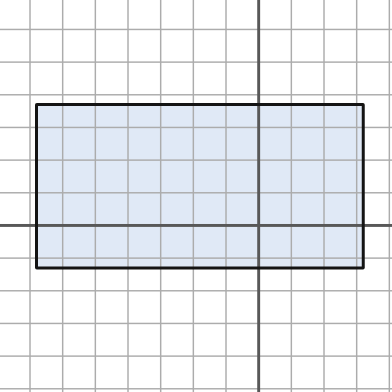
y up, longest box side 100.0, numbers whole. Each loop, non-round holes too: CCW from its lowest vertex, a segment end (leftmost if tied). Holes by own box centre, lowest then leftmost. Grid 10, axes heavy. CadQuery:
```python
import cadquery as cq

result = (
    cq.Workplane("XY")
    .moveTo(-68.0, -13.0)
    .lineTo(32.0, -13.0)
    .lineTo(32.0, 37.0)
    .lineTo(-68.0, 37.0)
    .close()
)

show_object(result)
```